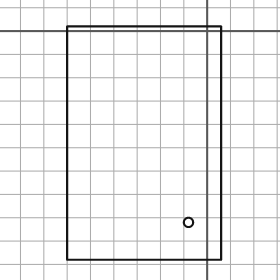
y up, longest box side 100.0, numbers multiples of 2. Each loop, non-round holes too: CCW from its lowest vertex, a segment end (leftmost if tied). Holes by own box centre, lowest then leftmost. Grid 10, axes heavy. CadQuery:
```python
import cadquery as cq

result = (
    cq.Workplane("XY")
    .moveTo(-60.0, -98.0)
    .lineTo(6.0, -98.0)
    .lineTo(6.0, 2.0)
    .lineTo(-60.0, 2.0)
    .close()
    .moveTo(-8.0, -82.0)
    .circle(2.0)
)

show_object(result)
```